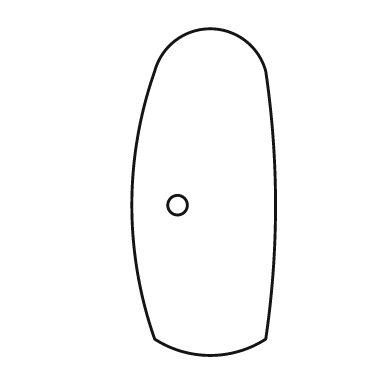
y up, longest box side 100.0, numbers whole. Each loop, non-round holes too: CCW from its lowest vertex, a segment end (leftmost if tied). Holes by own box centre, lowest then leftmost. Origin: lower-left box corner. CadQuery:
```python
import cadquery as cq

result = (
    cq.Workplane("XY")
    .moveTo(7.0, 5.0)
    .threePointArc((24.0, 0.0), (41.0, 5.0))
    .threePointArc((44.0, 46.0), (41.0, 87.0))
    .threePointArc((24.0, 100.0), (7.0, 87.0))
    .threePointArc((0.0, 46.0), (7.0, 5.0))
    .close()
    .moveTo(14.0, 46.0)
    .circle(3.0)
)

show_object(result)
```